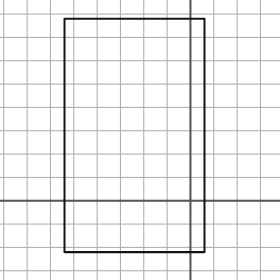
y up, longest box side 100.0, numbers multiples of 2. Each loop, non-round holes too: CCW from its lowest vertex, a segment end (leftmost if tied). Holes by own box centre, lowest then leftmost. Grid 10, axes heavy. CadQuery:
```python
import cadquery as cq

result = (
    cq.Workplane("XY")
    .moveTo(-54.0, -22.0)
    .lineTo(6.0, -22.0)
    .lineTo(6.0, 78.0)
    .lineTo(-54.0, 78.0)
    .close()
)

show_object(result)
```